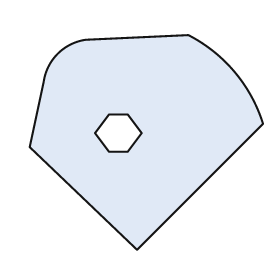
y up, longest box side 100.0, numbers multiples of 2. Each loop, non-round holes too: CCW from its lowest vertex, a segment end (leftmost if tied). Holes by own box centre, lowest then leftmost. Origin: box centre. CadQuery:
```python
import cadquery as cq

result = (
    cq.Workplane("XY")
    .moveTo(-4.0, -46.0)
    .lineTo(50.0, 8.0)
    .threePointArc((38.0, 30.0), (18.0, 46.0))
    .lineTo(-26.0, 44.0)
    .threePointArc((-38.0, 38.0), (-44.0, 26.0))
    .lineTo(-50.0, -2.0)
    .close()
    .moveTo(-16.0, -4.0)
    .lineTo(-8.0, -4.0)
    .lineTo(-2.0, 4.0)
    .lineTo(-8.0, 12.0)
    .lineTo(-16.0, 12.0)
    .lineTo(-22.0, 4.0)
    .close()
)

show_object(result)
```